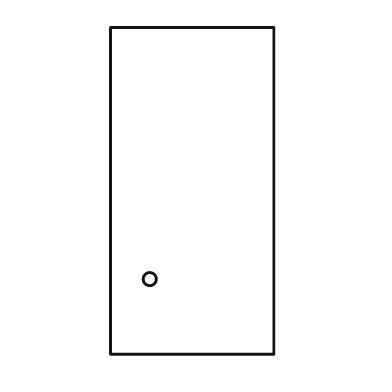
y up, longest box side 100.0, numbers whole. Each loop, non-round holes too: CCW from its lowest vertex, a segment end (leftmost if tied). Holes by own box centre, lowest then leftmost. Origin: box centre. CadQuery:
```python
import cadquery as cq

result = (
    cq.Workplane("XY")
    .moveTo(-25.0, -50.0)
    .lineTo(25.0, -50.0)
    .lineTo(25.0, 50.0)
    .lineTo(-25.0, 50.0)
    .close()
    .moveTo(-13.0, -27.0)
    .circle(2.0)
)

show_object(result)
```